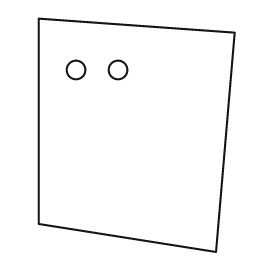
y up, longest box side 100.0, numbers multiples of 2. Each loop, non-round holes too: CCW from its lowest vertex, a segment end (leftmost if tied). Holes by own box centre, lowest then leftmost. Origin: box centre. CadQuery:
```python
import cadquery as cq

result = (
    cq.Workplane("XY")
    .moveTo(34.0, -50.0)
    .lineTo(42.0, 44.0)
    .lineTo(-42.0, 50.0)
    .lineTo(-42.0, -38.0)
    .close()
    .moveTo(-26.0, 28.0)
    .circle(4.0)
    .moveTo(-8.0, 28.0)
    .circle(4.0)
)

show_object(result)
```